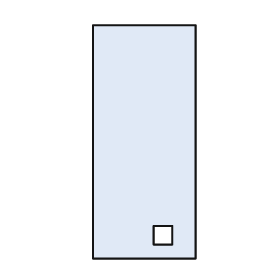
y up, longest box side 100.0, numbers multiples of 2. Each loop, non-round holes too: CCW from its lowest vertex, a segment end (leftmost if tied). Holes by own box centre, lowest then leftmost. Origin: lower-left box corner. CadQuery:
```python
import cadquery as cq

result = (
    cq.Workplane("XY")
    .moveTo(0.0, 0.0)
    .lineTo(44.0, 0.0)
    .lineTo(44.0, 100.0)
    .lineTo(0.0, 100.0)
    .close()
    .moveTo(26.0, 6.0)
    .lineTo(34.0, 6.0)
    .lineTo(34.0, 14.0)
    .lineTo(26.0, 14.0)
    .close()
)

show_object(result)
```